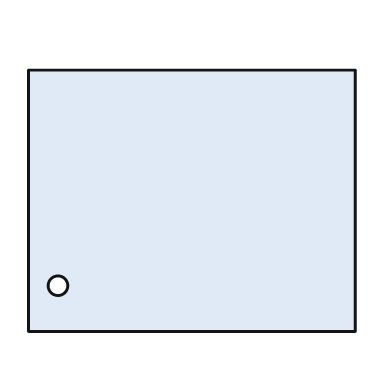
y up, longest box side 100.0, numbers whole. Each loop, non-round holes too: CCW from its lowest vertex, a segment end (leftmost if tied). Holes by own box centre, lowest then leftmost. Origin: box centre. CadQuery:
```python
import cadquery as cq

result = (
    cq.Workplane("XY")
    .moveTo(-50.0, -40.0)
    .lineTo(50.0, -40.0)
    .lineTo(50.0, 40.0)
    .lineTo(-50.0, 40.0)
    .close()
    .moveTo(-41.0, -26.0)
    .circle(3.0)
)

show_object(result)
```